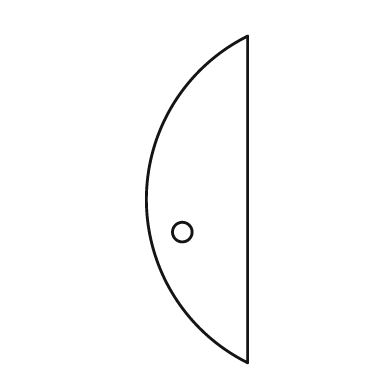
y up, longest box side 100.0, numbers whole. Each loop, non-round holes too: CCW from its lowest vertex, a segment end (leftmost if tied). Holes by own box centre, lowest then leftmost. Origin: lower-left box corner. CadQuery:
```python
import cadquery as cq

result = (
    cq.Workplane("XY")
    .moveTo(31.0, 0.0)
    .lineTo(31.0, 100.0)
    .threePointArc((0.0, 50.0), (31.0, 0.0))
    .close()
    .moveTo(11.0, 40.0)
    .circle(3.0)
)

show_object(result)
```